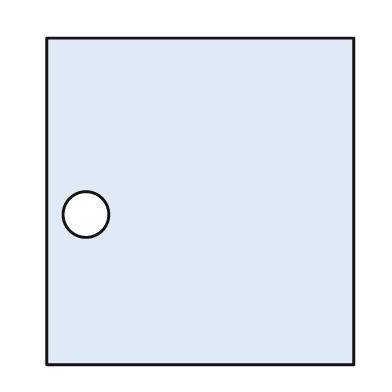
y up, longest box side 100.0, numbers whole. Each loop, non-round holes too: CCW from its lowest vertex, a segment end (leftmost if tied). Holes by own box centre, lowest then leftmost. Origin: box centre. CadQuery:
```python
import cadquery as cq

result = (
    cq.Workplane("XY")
    .moveTo(-47.0, -50.0)
    .lineTo(47.0, -50.0)
    .lineTo(47.0, 50.0)
    .lineTo(-47.0, 50.0)
    .close()
    .moveTo(-35.0, -4.0)
    .circle(7.0)
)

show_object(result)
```